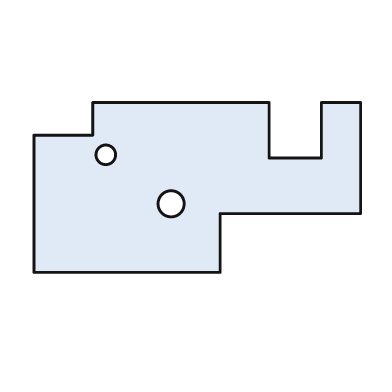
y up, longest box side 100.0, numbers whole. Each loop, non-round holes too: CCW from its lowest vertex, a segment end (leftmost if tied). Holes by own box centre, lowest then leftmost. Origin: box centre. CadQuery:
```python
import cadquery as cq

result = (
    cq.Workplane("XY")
    .moveTo(-50.0, -26.0)
    .lineTo(7.0, -26.0)
    .lineTo(7.0, -8.0)
    .lineTo(50.0, -8.0)
    .lineTo(50.0, 26.0)
    .lineTo(38.0, 26.0)
    .lineTo(38.0, 9.0)
    .lineTo(22.0, 9.0)
    .lineTo(22.0, 26.0)
    .lineTo(-32.0, 26.0)
    .lineTo(-32.0, 16.0)
    .lineTo(-50.0, 16.0)
    .close()
    .moveTo(-8.0, -5.0)
    .circle(4.0)
    .moveTo(-28.0, 10.0)
    .circle(3.0)
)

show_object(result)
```